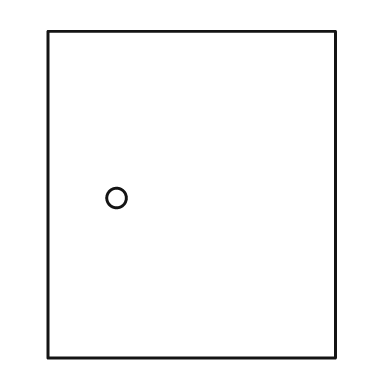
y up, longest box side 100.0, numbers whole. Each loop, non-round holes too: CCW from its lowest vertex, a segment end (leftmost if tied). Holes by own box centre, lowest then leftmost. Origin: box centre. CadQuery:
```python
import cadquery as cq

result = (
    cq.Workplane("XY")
    .moveTo(-44.0, -50.0)
    .lineTo(44.0, -50.0)
    .lineTo(44.0, 50.0)
    .lineTo(-44.0, 50.0)
    .close()
    .moveTo(-23.0, -1.0)
    .circle(3.0)
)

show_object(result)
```